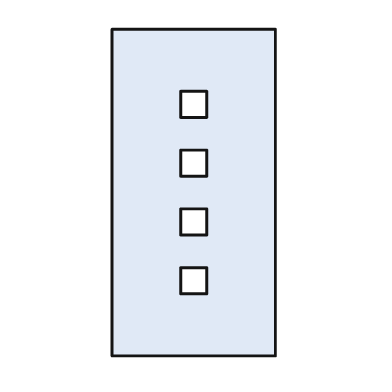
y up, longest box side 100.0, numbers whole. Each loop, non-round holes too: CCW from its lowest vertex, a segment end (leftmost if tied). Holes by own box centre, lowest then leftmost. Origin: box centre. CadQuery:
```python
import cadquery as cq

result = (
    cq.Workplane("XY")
    .moveTo(-25.0, -50.0)
    .lineTo(25.0, -50.0)
    .lineTo(25.0, 50.0)
    .lineTo(-25.0, 50.0)
    .close()
    .moveTo(-4.0, -31.0)
    .lineTo(4.0, -31.0)
    .lineTo(4.0, -23.0)
    .lineTo(-4.0, -23.0)
    .close()
    .moveTo(-4.0, -13.0)
    .lineTo(4.0, -13.0)
    .lineTo(4.0, -5.0)
    .lineTo(-4.0, -5.0)
    .close()
    .moveTo(-4.0, 5.0)
    .lineTo(4.0, 5.0)
    .lineTo(4.0, 13.0)
    .lineTo(-4.0, 13.0)
    .close()
    .moveTo(-4.0, 23.0)
    .lineTo(4.0, 23.0)
    .lineTo(4.0, 31.0)
    .lineTo(-4.0, 31.0)
    .close()
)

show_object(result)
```